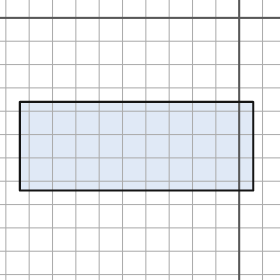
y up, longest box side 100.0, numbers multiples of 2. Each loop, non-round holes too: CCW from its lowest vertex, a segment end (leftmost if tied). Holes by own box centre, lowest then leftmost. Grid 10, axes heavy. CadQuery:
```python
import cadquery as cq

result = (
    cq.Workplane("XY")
    .moveTo(-94.0, -74.0)
    .lineTo(6.0, -74.0)
    .lineTo(6.0, -36.0)
    .lineTo(-94.0, -36.0)
    .close()
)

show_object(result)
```